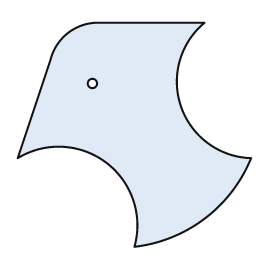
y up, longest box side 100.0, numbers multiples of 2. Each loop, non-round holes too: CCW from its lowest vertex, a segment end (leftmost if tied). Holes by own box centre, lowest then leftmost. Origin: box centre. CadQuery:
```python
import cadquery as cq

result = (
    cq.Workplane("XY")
    .moveTo(0.0, -48.0)
    .threePointArc((30.0, -36.0), (50.0, -10.0))
    .threePointArc((20.0, 12.0), (30.0, 48.0))
    .lineTo(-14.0, 48.0)
    .threePointArc((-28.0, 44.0), (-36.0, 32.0))
    .lineTo(-50.0, -10.0)
    .threePointArc((-12.0, -12.0), (0.0, -48.0))
    .close()
    .moveTo(-18.0, 22.0)
    .circle(2.0)
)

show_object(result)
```